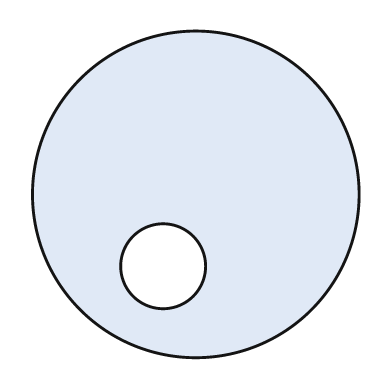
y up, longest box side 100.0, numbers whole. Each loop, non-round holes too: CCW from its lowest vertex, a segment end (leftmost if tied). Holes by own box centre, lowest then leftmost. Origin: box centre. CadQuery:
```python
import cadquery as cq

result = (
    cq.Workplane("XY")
    .moveTo(0.0, 0.0)
    .circle(50.0)
    .moveTo(-10.0, -22.0)
    .circle(13.0)
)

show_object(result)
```